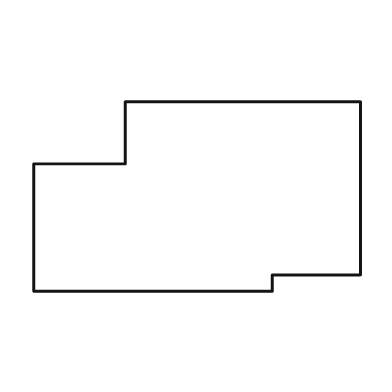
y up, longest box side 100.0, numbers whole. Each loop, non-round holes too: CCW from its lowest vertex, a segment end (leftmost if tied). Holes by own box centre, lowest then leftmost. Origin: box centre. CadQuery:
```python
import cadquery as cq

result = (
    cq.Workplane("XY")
    .moveTo(-50.0, -29.0)
    .lineTo(23.0, -29.0)
    .lineTo(23.0, -24.0)
    .lineTo(50.0, -24.0)
    .lineTo(50.0, 29.0)
    .lineTo(-22.0, 29.0)
    .lineTo(-22.0, 10.0)
    .lineTo(-50.0, 10.0)
    .close()
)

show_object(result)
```